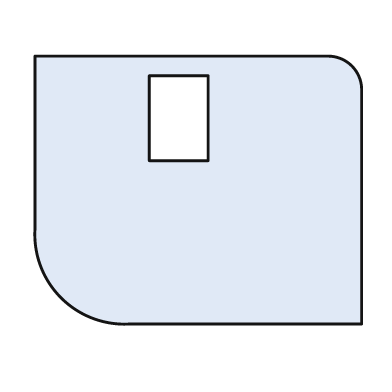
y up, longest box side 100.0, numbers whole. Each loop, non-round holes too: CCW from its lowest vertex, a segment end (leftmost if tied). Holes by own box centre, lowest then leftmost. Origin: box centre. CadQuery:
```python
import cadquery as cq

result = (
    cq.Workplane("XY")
    .moveTo(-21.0, -41.0)
    .lineTo(50.0, -41.0)
    .lineTo(50.0, 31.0)
    .threePointArc((47.0, 38.0), (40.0, 41.0))
    .lineTo(-50.0, 41.0)
    .lineTo(-50.0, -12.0)
    .threePointArc((-42.0, -33.0), (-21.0, -41.0))
    .close()
    .moveTo(-15.0, 9.0)
    .lineTo(3.0, 9.0)
    .lineTo(3.0, 35.0)
    .lineTo(-15.0, 35.0)
    .close()
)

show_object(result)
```